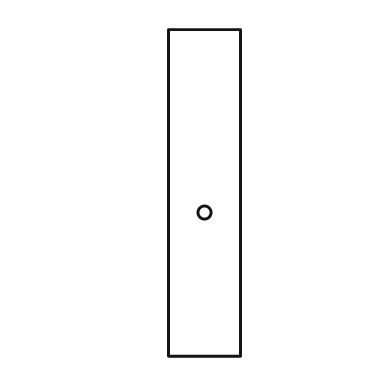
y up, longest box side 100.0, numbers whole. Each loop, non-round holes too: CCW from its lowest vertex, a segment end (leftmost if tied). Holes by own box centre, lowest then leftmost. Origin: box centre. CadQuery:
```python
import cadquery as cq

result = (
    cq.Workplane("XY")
    .moveTo(-11.0, -50.0)
    .lineTo(11.0, -50.0)
    .lineTo(11.0, 50.0)
    .lineTo(-11.0, 50.0)
    .close()
    .moveTo(0.0, -6.0)
    .circle(2.0)
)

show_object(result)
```